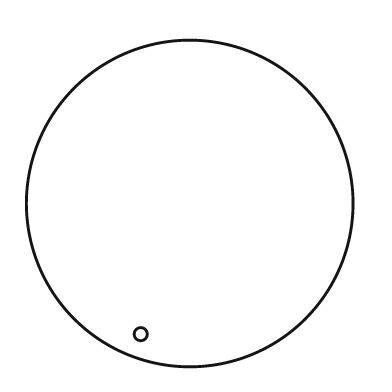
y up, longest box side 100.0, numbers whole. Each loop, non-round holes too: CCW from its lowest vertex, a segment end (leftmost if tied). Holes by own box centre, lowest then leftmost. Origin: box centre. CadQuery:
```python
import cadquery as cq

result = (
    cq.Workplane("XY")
    .moveTo(0.0, 0.0)
    .circle(50.0)
    .moveTo(-15.0, -40.0)
    .circle(2.0)
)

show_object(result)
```